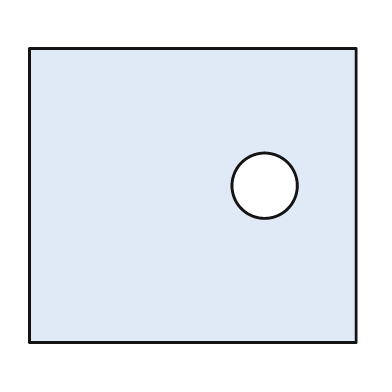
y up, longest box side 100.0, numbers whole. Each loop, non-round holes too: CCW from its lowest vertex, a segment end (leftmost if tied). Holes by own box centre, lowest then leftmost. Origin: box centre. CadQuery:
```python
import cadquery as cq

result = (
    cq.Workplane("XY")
    .moveTo(-50.0, -45.0)
    .lineTo(50.0, -45.0)
    .lineTo(50.0, 45.0)
    .lineTo(-50.0, 45.0)
    .close()
    .moveTo(22.0, 3.0)
    .circle(10.0)
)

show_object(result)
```